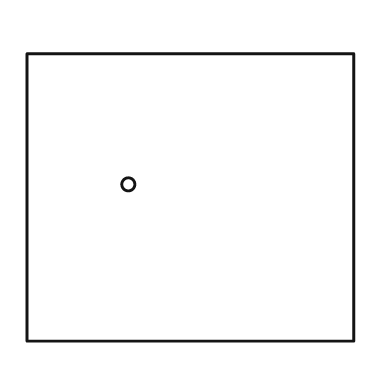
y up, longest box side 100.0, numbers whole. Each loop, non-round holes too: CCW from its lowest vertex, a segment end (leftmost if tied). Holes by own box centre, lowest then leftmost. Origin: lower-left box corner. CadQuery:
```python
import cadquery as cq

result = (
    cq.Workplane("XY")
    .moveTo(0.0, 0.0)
    .lineTo(100.0, 0.0)
    .lineTo(100.0, 88.0)
    .lineTo(0.0, 88.0)
    .close()
    .moveTo(31.0, 48.0)
    .circle(2.0)
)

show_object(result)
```